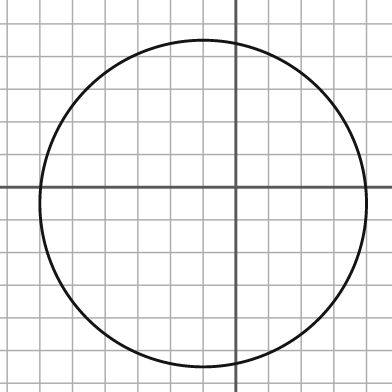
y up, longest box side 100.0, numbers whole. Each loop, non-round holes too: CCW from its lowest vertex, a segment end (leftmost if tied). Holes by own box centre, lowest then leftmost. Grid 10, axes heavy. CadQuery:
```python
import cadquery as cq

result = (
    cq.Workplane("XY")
    .moveTo(-10.0, -5.0)
    .circle(50.0)
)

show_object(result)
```